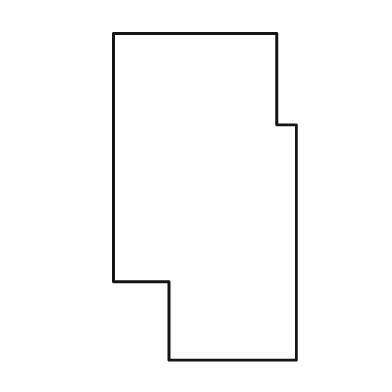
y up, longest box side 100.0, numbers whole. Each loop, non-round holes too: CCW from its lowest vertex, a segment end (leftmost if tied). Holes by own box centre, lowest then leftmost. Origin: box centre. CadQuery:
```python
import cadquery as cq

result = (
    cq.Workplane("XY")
    .moveTo(-11.0, -50.0)
    .lineTo(28.0, -50.0)
    .lineTo(28.0, 22.0)
    .lineTo(22.0, 22.0)
    .lineTo(22.0, 50.0)
    .lineTo(-28.0, 50.0)
    .lineTo(-28.0, -26.0)
    .lineTo(-11.0, -26.0)
    .close()
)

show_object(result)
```